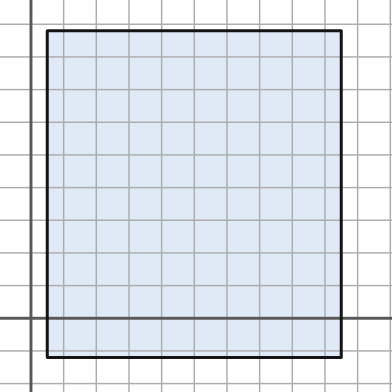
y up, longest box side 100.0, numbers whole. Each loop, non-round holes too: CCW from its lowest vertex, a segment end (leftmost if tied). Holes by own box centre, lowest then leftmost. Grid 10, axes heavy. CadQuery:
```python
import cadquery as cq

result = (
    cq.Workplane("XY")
    .moveTo(5.0, -12.0)
    .lineTo(95.0, -12.0)
    .lineTo(95.0, 88.0)
    .lineTo(5.0, 88.0)
    .close()
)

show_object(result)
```